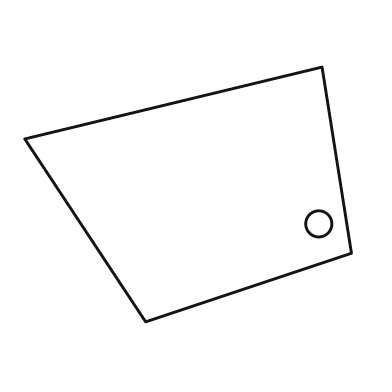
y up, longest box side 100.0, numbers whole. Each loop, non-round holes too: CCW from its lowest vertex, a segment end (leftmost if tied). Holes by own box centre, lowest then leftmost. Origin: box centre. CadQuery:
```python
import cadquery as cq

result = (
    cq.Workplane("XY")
    .moveTo(-13.0, -39.0)
    .lineTo(50.0, -18.0)
    .lineTo(41.0, 39.0)
    .lineTo(-50.0, 17.0)
    .close()
    .moveTo(40.0, -9.0)
    .circle(4.0)
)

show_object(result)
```